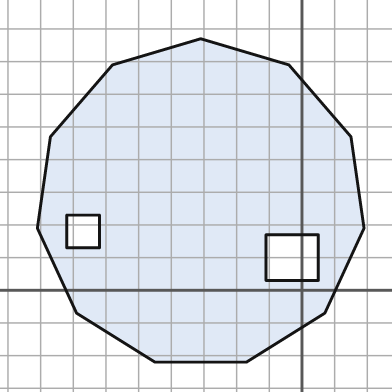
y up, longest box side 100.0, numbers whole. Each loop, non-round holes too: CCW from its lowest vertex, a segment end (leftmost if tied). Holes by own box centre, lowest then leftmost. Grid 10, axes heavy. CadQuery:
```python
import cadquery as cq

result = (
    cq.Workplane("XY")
    .moveTo(-45.0, -22.0)
    .lineTo(-17.0, -22.0)
    .lineTo(7.0, -7.0)
    .lineTo(19.0, 19.0)
    .lineTo(15.0, 47.0)
    .lineTo(-4.0, 69.0)
    .lineTo(-31.0, 77.0)
    .lineTo(-58.0, 69.0)
    .lineTo(-77.0, 47.0)
    .lineTo(-81.0, 19.0)
    .lineTo(-69.0, -7.0)
    .close()
    .moveTo(-11.0, 3.0)
    .lineTo(5.0, 3.0)
    .lineTo(5.0, 17.0)
    .lineTo(-11.0, 17.0)
    .close()
    .moveTo(-72.0, 13.0)
    .lineTo(-62.0, 13.0)
    .lineTo(-62.0, 23.0)
    .lineTo(-72.0, 23.0)
    .close()
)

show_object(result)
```